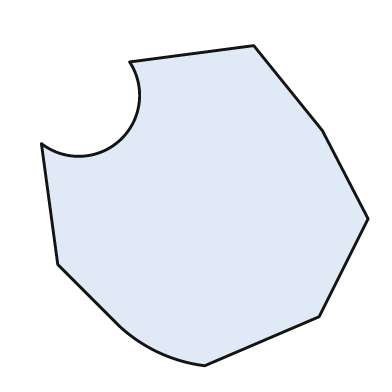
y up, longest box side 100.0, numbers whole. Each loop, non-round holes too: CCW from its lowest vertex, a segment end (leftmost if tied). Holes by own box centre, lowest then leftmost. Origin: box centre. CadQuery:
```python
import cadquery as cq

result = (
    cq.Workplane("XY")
    .moveTo(0.0, -49.0)
    .lineTo(35.0, -34.0)
    .lineTo(50.0, -4.0)
    .lineTo(36.0, 23.0)
    .lineTo(15.0, 49.0)
    .lineTo(-23.0, 44.0)
    .threePointArc((-26.0, 20.0), (-50.0, 19.0))
    .lineTo(-45.0, -18.0)
    .lineTo(-26.0, -37.0)
    .threePointArc((-14.0, -45.0), (0.0, -49.0))
    .close()
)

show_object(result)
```